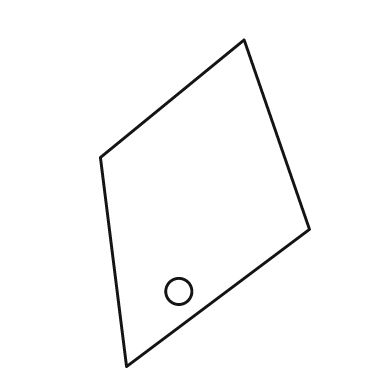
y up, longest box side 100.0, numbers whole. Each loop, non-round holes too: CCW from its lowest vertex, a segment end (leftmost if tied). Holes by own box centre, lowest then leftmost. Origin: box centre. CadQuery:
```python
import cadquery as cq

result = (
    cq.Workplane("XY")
    .moveTo(-24.0, -50.0)
    .lineTo(32.0, -8.0)
    .lineTo(12.0, 50.0)
    .lineTo(-32.0, 14.0)
    .close()
    .moveTo(-8.0, -27.0)
    .circle(4.0)
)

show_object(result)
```